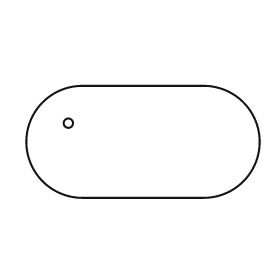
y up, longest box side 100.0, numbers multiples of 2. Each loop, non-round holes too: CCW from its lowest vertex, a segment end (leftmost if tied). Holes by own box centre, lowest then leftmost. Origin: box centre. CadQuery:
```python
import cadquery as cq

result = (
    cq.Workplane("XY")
    .moveTo(-26.0, -24.0)
    .lineTo(26.0, -24.0)
    .threePointArc((50.0, 0.0), (26.0, 24.0))
    .lineTo(-26.0, 24.0)
    .threePointArc((-50.0, 0.0), (-26.0, -24.0))
    .close()
    .moveTo(-32.0, 8.0)
    .circle(2.0)
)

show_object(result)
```